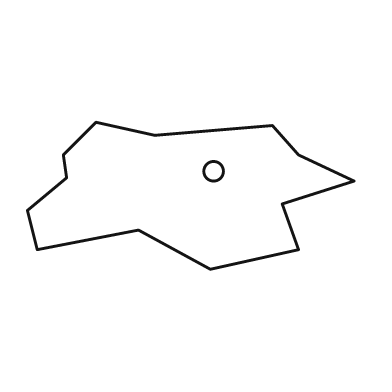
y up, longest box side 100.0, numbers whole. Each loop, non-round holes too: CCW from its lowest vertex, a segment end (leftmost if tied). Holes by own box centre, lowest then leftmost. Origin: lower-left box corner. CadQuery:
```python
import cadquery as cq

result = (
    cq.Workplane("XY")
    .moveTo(56.0, 0.0)
    .lineTo(83.0, 6.0)
    .lineTo(78.0, 20.0)
    .lineTo(100.0, 27.0)
    .lineTo(83.0, 35.0)
    .lineTo(75.0, 44.0)
    .lineTo(39.0, 41.0)
    .lineTo(21.0, 45.0)
    .lineTo(11.0, 35.0)
    .lineTo(12.0, 28.0)
    .lineTo(0.0, 18.0)
    .lineTo(3.0, 6.0)
    .lineTo(34.0, 12.0)
    .close()
    .moveTo(57.0, 30.0)
    .circle(3.0)
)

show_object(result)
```